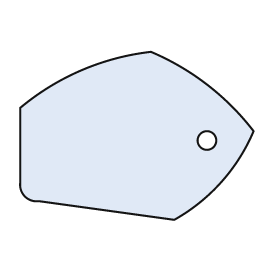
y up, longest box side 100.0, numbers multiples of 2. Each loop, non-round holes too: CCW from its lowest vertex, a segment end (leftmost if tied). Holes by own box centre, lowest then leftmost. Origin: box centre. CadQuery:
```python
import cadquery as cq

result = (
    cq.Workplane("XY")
    .moveTo(16.0, -36.0)
    .threePointArc((36.0, -20.0), (50.0, 2.0))
    .threePointArc((30.0, 22.0), (6.0, 36.0))
    .threePointArc((-24.0, 28.0), (-50.0, 12.0))
    .lineTo(-50.0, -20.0)
    .threePointArc((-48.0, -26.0), (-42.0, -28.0))
    .close()
    .moveTo(30.0, -2.0)
    .circle(4.0)
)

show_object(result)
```